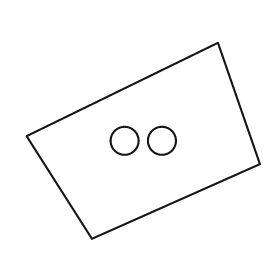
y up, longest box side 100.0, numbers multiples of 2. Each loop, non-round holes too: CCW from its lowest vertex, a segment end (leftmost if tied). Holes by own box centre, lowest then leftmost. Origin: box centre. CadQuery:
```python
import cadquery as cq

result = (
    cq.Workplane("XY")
    .moveTo(-22.0, -42.0)
    .lineTo(50.0, -10.0)
    .lineTo(32.0, 42.0)
    .lineTo(-50.0, 2.0)
    .close()
    .moveTo(-8.0, 0.0)
    .circle(6.0)
    .moveTo(8.0, 0.0)
    .circle(6.0)
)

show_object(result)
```